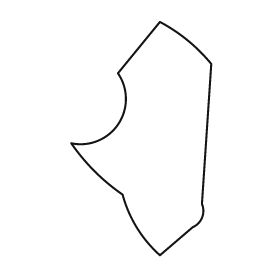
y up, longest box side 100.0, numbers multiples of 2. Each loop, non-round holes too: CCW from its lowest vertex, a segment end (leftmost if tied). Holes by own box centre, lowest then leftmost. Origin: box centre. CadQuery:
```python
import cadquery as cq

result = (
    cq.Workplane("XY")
    .moveTo(8.0, -50.0)
    .lineTo(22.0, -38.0)
    .threePointArc((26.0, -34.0), (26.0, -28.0))
    .lineTo(30.0, 32.0)
    .threePointArc((20.0, 42.0), (8.0, 50.0))
    .lineTo(-10.0, 28.0)
    .threePointArc((-10.0, 6.0), (-30.0, -2.0))
    .threePointArc((-20.0, -14.0), (-8.0, -24.0))
    .threePointArc((-2.0, -38.0), (8.0, -50.0))
    .close()
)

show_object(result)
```